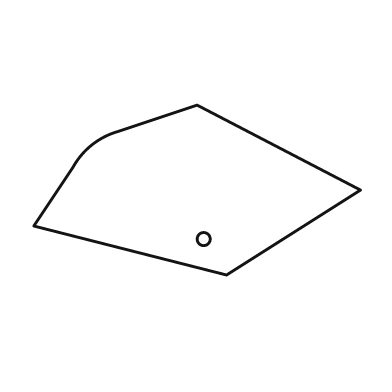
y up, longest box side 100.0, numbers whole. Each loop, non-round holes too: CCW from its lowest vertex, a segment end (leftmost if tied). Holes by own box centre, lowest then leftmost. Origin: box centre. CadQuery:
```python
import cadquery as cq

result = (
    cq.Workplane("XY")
    .moveTo(9.0, -26.0)
    .lineTo(50.0, 0.0)
    .lineTo(0.0, 26.0)
    .lineTo(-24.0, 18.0)
    .threePointArc((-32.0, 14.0), (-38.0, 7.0))
    .lineTo(-50.0, -11.0)
    .close()
    .moveTo(2.0, -15.0)
    .circle(2.0)
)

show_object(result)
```